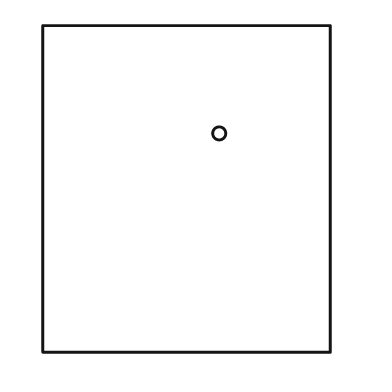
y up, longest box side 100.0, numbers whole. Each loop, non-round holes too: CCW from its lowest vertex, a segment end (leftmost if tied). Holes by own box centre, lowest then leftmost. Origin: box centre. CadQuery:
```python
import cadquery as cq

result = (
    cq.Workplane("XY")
    .moveTo(-44.0, -50.0)
    .lineTo(44.0, -50.0)
    .lineTo(44.0, 50.0)
    .lineTo(-44.0, 50.0)
    .close()
    .moveTo(10.0, 17.0)
    .circle(2.0)
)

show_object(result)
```